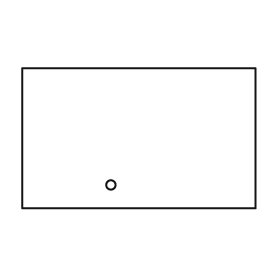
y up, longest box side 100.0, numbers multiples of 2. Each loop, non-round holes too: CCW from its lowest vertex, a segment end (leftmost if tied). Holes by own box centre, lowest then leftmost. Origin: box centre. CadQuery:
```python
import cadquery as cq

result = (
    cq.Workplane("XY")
    .moveTo(-50.0, -30.0)
    .lineTo(50.0, -30.0)
    .lineTo(50.0, 30.0)
    .lineTo(-50.0, 30.0)
    .close()
    .moveTo(-12.0, -20.0)
    .circle(2.0)
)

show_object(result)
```